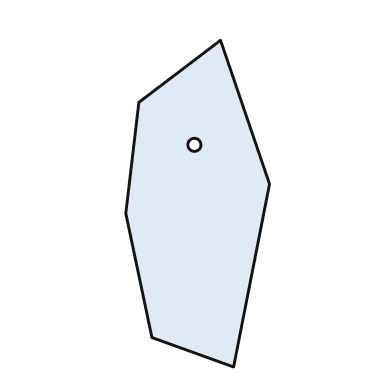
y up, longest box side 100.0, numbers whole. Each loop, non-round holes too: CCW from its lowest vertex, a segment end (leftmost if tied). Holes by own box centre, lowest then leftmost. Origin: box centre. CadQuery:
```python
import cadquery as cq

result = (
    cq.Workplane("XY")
    .moveTo(11.0, -50.0)
    .lineTo(22.0, 6.0)
    .lineTo(7.0, 50.0)
    .lineTo(-18.0, 31.0)
    .lineTo(-22.0, -3.0)
    .lineTo(-14.0, -41.0)
    .close()
    .moveTo(-1.0, 18.0)
    .circle(2.0)
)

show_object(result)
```